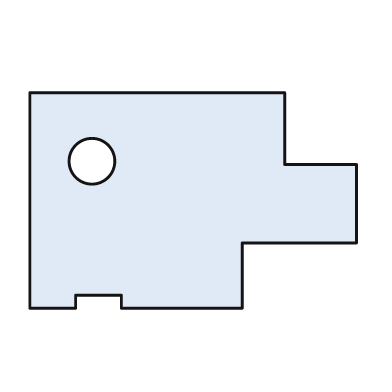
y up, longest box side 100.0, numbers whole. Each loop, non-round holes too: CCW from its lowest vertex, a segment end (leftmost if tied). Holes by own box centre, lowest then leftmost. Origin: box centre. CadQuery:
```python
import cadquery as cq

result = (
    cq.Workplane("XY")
    .moveTo(-50.0, -33.0)
    .lineTo(-36.0, -33.0)
    .lineTo(-36.0, -29.0)
    .lineTo(-22.0, -29.0)
    .lineTo(-22.0, -33.0)
    .lineTo(15.0, -33.0)
    .lineTo(15.0, -13.0)
    .lineTo(50.0, -13.0)
    .lineTo(50.0, 11.0)
    .lineTo(28.0, 11.0)
    .lineTo(28.0, 33.0)
    .lineTo(-50.0, 33.0)
    .close()
    .moveTo(-31.0, 12.0)
    .circle(7.0)
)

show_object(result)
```